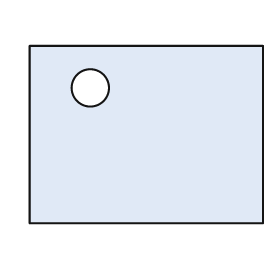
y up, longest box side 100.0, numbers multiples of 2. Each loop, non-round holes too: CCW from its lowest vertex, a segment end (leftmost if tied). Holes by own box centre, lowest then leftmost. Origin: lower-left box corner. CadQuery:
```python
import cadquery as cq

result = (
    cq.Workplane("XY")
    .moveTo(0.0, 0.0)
    .lineTo(100.0, 0.0)
    .lineTo(100.0, 76.0)
    .lineTo(0.0, 76.0)
    .close()
    .moveTo(26.0, 58.0)
    .circle(8.0)
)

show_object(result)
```